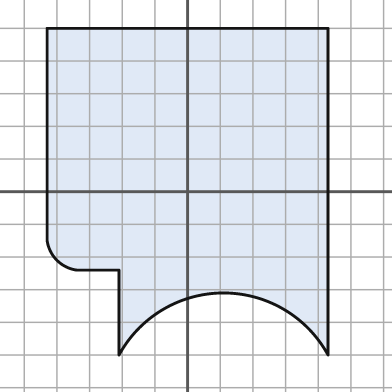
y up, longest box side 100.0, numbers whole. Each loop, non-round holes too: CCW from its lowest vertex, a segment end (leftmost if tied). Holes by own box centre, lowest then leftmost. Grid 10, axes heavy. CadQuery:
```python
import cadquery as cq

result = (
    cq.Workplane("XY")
    .moveTo(-21.0, -50.0)
    .threePointArc((11.0, -31.0), (43.0, -50.0))
    .lineTo(43.0, 50.0)
    .lineTo(-43.0, 50.0)
    .lineTo(-43.0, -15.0)
    .threePointArc((-40.0, -21.0), (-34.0, -24.0))
    .lineTo(-21.0, -24.0)
    .close()
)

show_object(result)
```